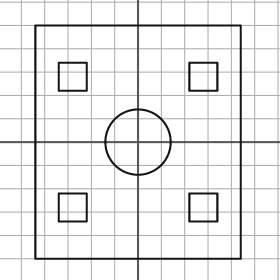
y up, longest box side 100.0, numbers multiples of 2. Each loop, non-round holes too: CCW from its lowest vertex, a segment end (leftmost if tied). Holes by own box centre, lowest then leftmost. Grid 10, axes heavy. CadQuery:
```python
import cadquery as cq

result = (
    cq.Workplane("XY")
    .moveTo(-44.0, -50.0)
    .lineTo(44.0, -50.0)
    .lineTo(44.0, 50.0)
    .lineTo(-44.0, 50.0)
    .close()
    .moveTo(-34.0, -34.0)
    .lineTo(-22.0, -34.0)
    .lineTo(-22.0, -22.0)
    .lineTo(-34.0, -22.0)
    .close()
    .moveTo(22.0, -34.0)
    .lineTo(34.0, -34.0)
    .lineTo(34.0, -22.0)
    .lineTo(22.0, -22.0)
    .close()
    .moveTo(0.0, 0.0)
    .circle(14.0)
    .moveTo(-34.0, 22.0)
    .lineTo(-22.0, 22.0)
    .lineTo(-22.0, 34.0)
    .lineTo(-34.0, 34.0)
    .close()
    .moveTo(22.0, 22.0)
    .lineTo(34.0, 22.0)
    .lineTo(34.0, 34.0)
    .lineTo(22.0, 34.0)
    .close()
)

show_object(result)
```